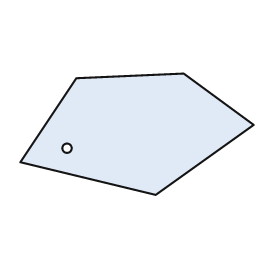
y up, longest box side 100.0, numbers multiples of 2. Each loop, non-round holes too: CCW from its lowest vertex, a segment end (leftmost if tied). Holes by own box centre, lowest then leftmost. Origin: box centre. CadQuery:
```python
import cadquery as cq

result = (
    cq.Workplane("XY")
    .moveTo(8.0, -26.0)
    .lineTo(50.0, 4.0)
    .lineTo(20.0, 26.0)
    .lineTo(-26.0, 24.0)
    .lineTo(-50.0, -12.0)
    .close()
    .moveTo(-30.0, -6.0)
    .circle(2.0)
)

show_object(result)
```